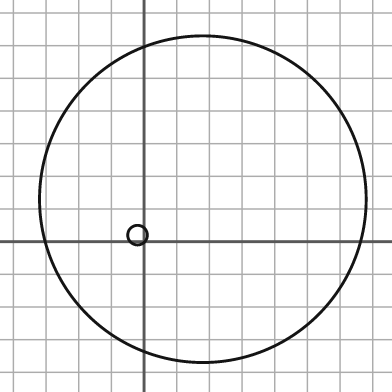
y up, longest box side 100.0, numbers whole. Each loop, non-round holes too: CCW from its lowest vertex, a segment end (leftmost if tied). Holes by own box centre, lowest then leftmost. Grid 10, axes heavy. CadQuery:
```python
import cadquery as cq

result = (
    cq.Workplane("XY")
    .moveTo(18.0, 13.0)
    .circle(50.0)
    .moveTo(-2.0, 2.0)
    .circle(3.0)
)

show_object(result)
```